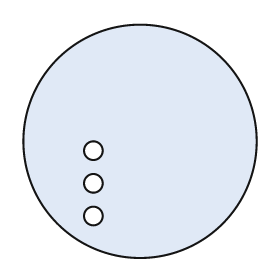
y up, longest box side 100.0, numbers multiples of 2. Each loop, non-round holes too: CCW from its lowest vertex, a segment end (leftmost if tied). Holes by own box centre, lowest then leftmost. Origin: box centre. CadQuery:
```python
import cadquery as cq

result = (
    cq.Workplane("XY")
    .moveTo(0.0, 0.0)
    .circle(50.0)
    .moveTo(-20.0, -32.0)
    .circle(4.0)
    .moveTo(-20.0, -18.0)
    .circle(4.0)
    .moveTo(-20.0, -4.0)
    .circle(4.0)
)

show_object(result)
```